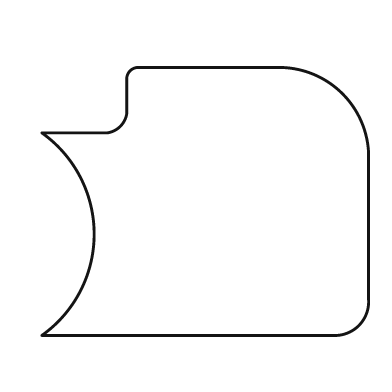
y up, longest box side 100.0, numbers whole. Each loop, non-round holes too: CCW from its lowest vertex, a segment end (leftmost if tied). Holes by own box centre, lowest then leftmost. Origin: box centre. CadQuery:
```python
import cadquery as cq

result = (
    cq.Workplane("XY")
    .moveTo(-50.0, -41.0)
    .lineTo(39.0, -41.0)
    .threePointArc((47.0, -38.0), (50.0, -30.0))
    .lineTo(50.0, 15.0)
    .threePointArc((42.0, 33.0), (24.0, 41.0))
    .lineTo(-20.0, 41.0)
    .threePointArc((-23.0, 40.0), (-24.0, 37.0))
    .lineTo(-24.0, 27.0)
    .threePointArc((-26.0, 23.0), (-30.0, 21.0))
    .lineTo(-50.0, 21.0)
    .threePointArc((-34.0, -10.0), (-50.0, -41.0))
    .close()
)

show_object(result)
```